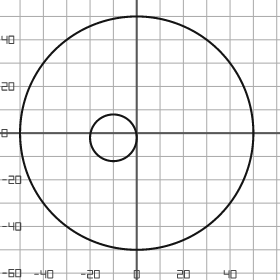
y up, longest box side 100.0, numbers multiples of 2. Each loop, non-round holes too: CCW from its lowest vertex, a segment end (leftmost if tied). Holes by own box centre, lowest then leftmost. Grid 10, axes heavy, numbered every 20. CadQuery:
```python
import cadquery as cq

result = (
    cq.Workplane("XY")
    .moveTo(0.0, 0.0)
    .circle(50.0)
    .moveTo(-10.0, -2.0)
    .circle(10.0)
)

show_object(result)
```